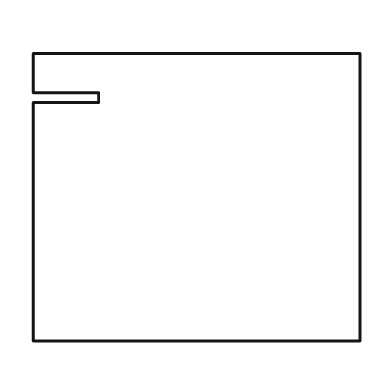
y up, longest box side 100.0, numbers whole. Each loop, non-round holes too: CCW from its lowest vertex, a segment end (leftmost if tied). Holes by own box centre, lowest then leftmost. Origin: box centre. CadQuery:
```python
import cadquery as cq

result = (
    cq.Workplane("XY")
    .moveTo(-50.0, -44.0)
    .lineTo(50.0, -44.0)
    .lineTo(50.0, 44.0)
    .lineTo(-50.0, 44.0)
    .lineTo(-50.0, 32.0)
    .lineTo(-30.0, 32.0)
    .lineTo(-30.0, 29.0)
    .lineTo(-50.0, 29.0)
    .close()
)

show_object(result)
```